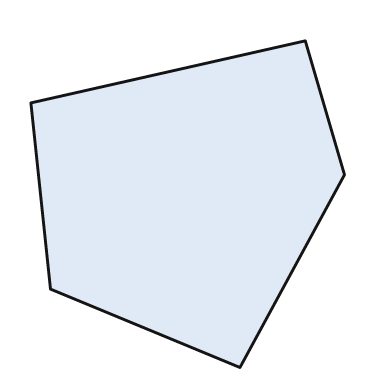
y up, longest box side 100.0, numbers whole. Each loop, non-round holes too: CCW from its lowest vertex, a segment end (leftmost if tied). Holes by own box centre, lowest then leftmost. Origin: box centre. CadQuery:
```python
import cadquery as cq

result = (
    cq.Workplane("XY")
    .moveTo(16.0, -50.0)
    .lineTo(48.0, 9.0)
    .lineTo(36.0, 50.0)
    .lineTo(-48.0, 31.0)
    .lineTo(-42.0, -26.0)
    .close()
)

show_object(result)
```